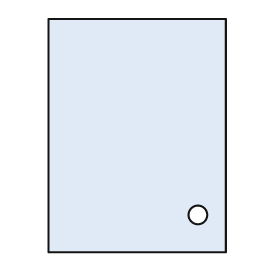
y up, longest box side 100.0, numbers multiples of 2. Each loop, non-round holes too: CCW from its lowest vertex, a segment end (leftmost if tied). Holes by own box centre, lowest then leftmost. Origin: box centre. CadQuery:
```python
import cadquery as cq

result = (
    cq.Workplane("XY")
    .moveTo(-38.0, -50.0)
    .lineTo(38.0, -50.0)
    .lineTo(38.0, 50.0)
    .lineTo(-38.0, 50.0)
    .close()
    .moveTo(26.0, -34.0)
    .circle(4.0)
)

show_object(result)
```